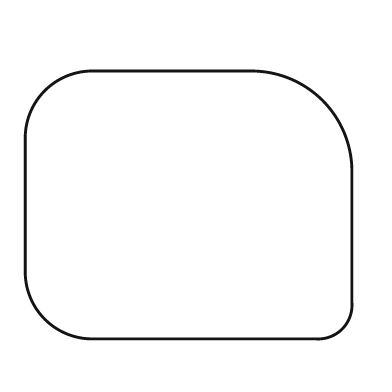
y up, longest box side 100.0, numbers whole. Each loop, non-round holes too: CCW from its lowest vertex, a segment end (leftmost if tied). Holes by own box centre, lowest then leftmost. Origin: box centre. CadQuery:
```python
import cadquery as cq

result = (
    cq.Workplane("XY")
    .moveTo(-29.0, -41.0)
    .lineTo(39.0, -41.0)
    .threePointArc((47.0, -38.0), (50.0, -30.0))
    .lineTo(50.0, 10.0)
    .threePointArc((41.0, 32.0), (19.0, 41.0))
    .lineTo(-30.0, 41.0)
    .threePointArc((-44.0, 35.0), (-50.0, 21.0))
    .lineTo(-50.0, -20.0)
    .threePointArc((-44.0, -35.0), (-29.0, -41.0))
    .close()
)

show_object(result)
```